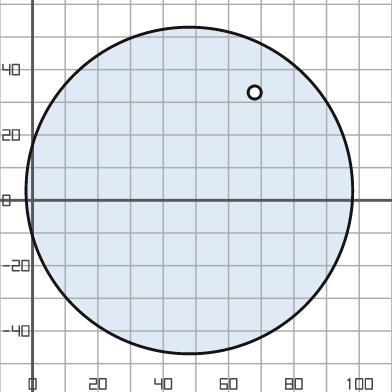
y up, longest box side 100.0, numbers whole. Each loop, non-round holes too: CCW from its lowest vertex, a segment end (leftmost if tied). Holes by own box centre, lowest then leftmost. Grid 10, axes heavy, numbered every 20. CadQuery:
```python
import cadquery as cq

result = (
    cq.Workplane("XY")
    .moveTo(48.0, 3.0)
    .circle(50.0)
    .moveTo(68.0, 33.0)
    .circle(2.0)
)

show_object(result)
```